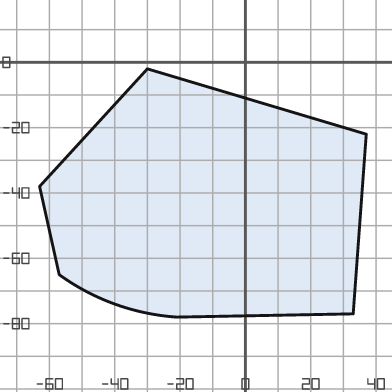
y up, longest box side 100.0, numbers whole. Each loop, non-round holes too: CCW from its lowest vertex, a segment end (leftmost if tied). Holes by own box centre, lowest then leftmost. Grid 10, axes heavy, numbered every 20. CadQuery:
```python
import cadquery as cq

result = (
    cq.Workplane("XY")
    .moveTo(-21.0, -78.0)
    .lineTo(33.0, -77.0)
    .lineTo(37.0, -22.0)
    .lineTo(-30.0, -2.0)
    .lineTo(-63.0, -38.0)
    .lineTo(-57.0, -65.0)
    .threePointArc((-40.0, -74.0), (-21.0, -78.0))
    .close()
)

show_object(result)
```